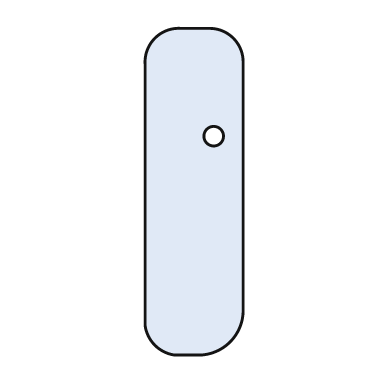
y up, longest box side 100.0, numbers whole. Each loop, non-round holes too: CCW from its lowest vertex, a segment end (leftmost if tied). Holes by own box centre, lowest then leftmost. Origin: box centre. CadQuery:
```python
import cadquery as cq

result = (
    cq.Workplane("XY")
    .moveTo(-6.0, -50.0)
    .lineTo(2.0, -50.0)
    .threePointArc((11.0, -46.0), (15.0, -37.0))
    .lineTo(15.0, 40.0)
    .threePointArc((12.0, 47.0), (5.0, 50.0))
    .lineTo(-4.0, 50.0)
    .threePointArc((-12.0, 47.0), (-15.0, 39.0))
    .lineTo(-15.0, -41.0)
    .threePointArc((-12.0, -47.0), (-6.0, -50.0))
    .close()
    .moveTo(6.0, 17.0)
    .circle(3.0)
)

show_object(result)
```